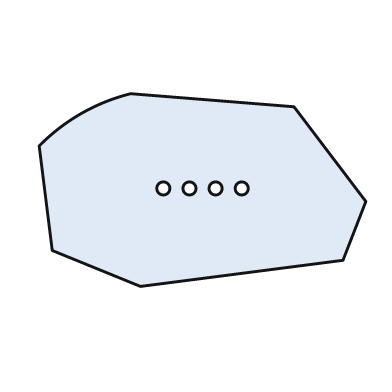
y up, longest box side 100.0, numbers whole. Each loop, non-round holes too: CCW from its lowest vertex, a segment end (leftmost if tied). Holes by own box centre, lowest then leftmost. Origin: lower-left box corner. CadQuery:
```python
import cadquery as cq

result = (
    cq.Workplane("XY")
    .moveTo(31.0, 0.0)
    .lineTo(93.0, 8.0)
    .lineTo(100.0, 26.0)
    .lineTo(78.0, 55.0)
    .lineTo(28.0, 59.0)
    .threePointArc((13.0, 53.0), (0.0, 43.0))
    .lineTo(4.0, 11.0)
    .close()
    .moveTo(38.0, 30.0)
    .circle(2.0)
    .moveTo(46.0, 30.0)
    .circle(2.0)
    .moveTo(54.0, 30.0)
    .circle(2.0)
    .moveTo(62.0, 30.0)
    .circle(2.0)
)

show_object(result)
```